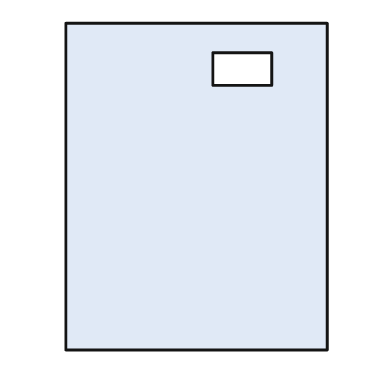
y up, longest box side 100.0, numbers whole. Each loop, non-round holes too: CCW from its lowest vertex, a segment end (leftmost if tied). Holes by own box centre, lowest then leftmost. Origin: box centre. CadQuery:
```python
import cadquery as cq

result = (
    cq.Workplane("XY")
    .moveTo(-40.0, -50.0)
    .lineTo(40.0, -50.0)
    .lineTo(40.0, 50.0)
    .lineTo(-40.0, 50.0)
    .close()
    .moveTo(5.0, 31.0)
    .lineTo(23.0, 31.0)
    .lineTo(23.0, 41.0)
    .lineTo(5.0, 41.0)
    .close()
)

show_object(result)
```